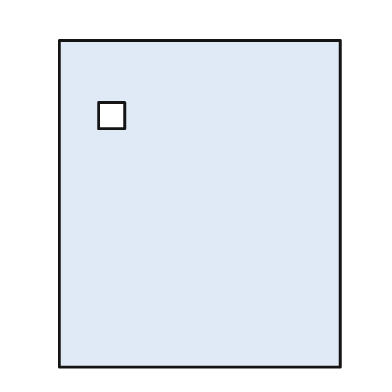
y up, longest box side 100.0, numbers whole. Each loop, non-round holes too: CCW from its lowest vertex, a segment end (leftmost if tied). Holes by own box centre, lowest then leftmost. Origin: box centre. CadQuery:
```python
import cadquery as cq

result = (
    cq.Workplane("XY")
    .moveTo(-43.0, -50.0)
    .lineTo(43.0, -50.0)
    .lineTo(43.0, 50.0)
    .lineTo(-43.0, 50.0)
    .close()
    .moveTo(-31.0, 23.0)
    .lineTo(-23.0, 23.0)
    .lineTo(-23.0, 31.0)
    .lineTo(-31.0, 31.0)
    .close()
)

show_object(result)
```